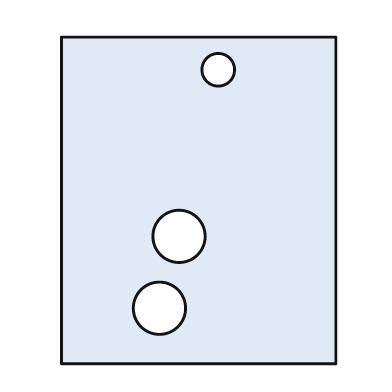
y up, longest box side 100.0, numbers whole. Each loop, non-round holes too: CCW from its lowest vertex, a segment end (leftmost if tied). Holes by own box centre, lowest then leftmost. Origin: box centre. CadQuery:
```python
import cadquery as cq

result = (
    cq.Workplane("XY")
    .moveTo(-42.0, -50.0)
    .lineTo(42.0, -50.0)
    .lineTo(42.0, 50.0)
    .lineTo(-42.0, 50.0)
    .close()
    .moveTo(-12.0, -33.0)
    .circle(8.0)
    .moveTo(-6.0, -11.0)
    .circle(8.0)
    .moveTo(6.0, 40.0)
    .circle(5.0)
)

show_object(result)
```